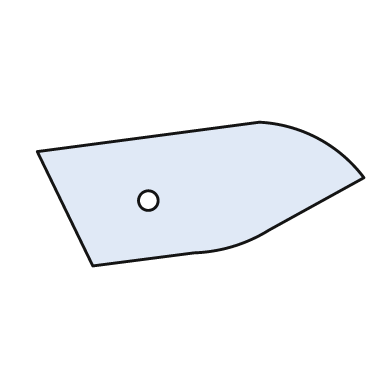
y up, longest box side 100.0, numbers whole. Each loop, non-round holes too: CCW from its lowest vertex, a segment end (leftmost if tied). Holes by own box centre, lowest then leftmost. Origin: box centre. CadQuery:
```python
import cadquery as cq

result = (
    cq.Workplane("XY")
    .moveTo(-33.0, -22.0)
    .lineTo(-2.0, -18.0)
    .threePointArc((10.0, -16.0), (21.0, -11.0))
    .lineTo(50.0, 5.0)
    .threePointArc((36.0, 17.0), (18.0, 22.0))
    .lineTo(-50.0, 13.0)
    .close()
    .moveTo(-16.0, -2.0)
    .circle(3.0)
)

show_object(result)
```